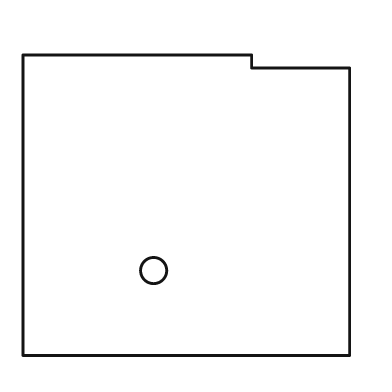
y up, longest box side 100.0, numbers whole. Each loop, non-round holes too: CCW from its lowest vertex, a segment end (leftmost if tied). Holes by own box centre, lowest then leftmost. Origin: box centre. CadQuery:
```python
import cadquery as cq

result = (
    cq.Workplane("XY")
    .moveTo(-50.0, -46.0)
    .lineTo(50.0, -46.0)
    .lineTo(50.0, 42.0)
    .lineTo(20.0, 42.0)
    .lineTo(20.0, 46.0)
    .lineTo(-50.0, 46.0)
    .close()
    .moveTo(-10.0, -20.0)
    .circle(4.0)
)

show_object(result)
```